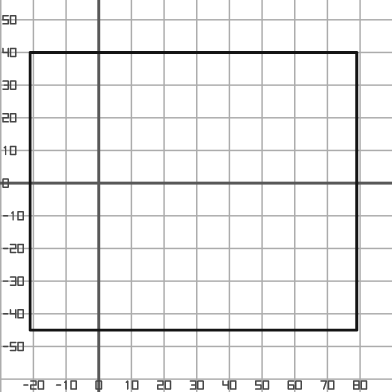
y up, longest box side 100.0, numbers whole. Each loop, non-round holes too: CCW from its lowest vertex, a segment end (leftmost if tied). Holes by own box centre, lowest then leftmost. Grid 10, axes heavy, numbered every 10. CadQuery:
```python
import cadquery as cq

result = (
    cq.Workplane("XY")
    .moveTo(-21.0, -45.0)
    .lineTo(79.0, -45.0)
    .lineTo(79.0, 40.0)
    .lineTo(-21.0, 40.0)
    .close()
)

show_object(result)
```